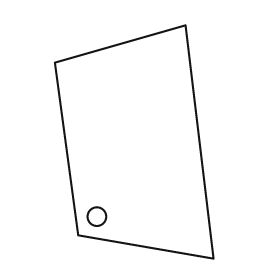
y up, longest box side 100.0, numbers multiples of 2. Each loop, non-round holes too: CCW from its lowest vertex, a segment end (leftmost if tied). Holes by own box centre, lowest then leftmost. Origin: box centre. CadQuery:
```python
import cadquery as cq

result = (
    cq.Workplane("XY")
    .moveTo(34.0, -50.0)
    .lineTo(22.0, 50.0)
    .lineTo(-34.0, 34.0)
    .lineTo(-24.0, -40.0)
    .close()
    .moveTo(-16.0, -32.0)
    .circle(4.0)
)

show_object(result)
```